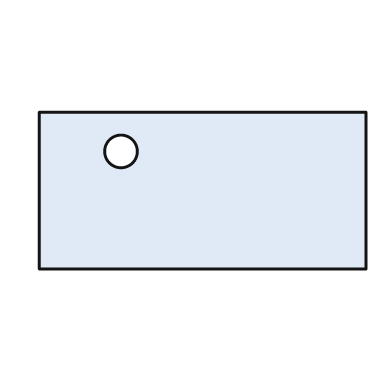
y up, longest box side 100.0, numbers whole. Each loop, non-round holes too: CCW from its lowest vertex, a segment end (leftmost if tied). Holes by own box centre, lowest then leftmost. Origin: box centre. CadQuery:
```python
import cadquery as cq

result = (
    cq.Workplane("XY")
    .moveTo(-50.0, -24.0)
    .lineTo(50.0, -24.0)
    .lineTo(50.0, 24.0)
    .lineTo(-50.0, 24.0)
    .close()
    .moveTo(-25.0, 12.0)
    .circle(5.0)
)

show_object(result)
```